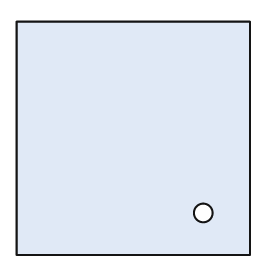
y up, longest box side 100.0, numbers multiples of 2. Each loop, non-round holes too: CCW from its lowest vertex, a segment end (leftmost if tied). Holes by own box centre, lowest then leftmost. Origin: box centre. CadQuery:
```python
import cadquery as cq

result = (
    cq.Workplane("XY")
    .moveTo(-50.0, -50.0)
    .lineTo(50.0, -50.0)
    .lineTo(50.0, 50.0)
    .lineTo(-50.0, 50.0)
    .close()
    .moveTo(30.0, -32.0)
    .circle(4.0)
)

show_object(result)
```